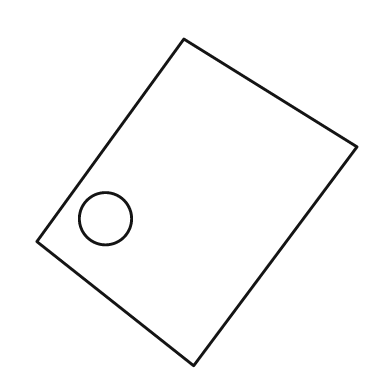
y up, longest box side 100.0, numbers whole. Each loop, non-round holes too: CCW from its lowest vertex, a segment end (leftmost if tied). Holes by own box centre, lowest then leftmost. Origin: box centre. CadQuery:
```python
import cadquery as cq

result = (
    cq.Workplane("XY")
    .moveTo(-1.0, -50.0)
    .lineTo(49.0, 17.0)
    .lineTo(-4.0, 50.0)
    .lineTo(-49.0, -12.0)
    .close()
    .moveTo(-28.0, -5.0)
    .circle(8.0)
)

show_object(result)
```